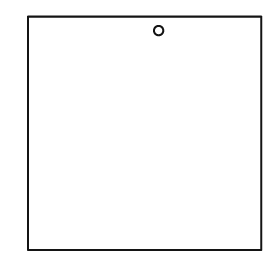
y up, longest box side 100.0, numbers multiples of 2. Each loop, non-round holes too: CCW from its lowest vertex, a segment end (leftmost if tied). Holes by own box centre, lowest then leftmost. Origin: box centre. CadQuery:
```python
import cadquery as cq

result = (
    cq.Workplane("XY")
    .moveTo(-50.0, -50.0)
    .lineTo(50.0, -50.0)
    .lineTo(50.0, 50.0)
    .lineTo(-50.0, 50.0)
    .close()
    .moveTo(6.0, 44.0)
    .circle(2.0)
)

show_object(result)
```